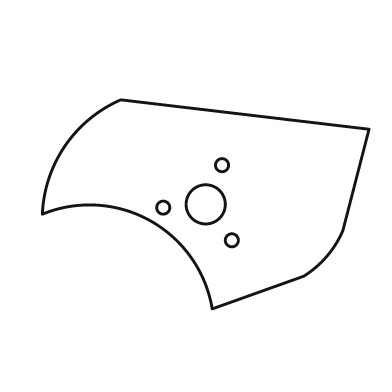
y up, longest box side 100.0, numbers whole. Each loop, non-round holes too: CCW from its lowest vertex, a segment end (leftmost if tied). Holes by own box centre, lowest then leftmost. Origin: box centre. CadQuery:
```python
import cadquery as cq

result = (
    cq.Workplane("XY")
    .moveTo(2.0, -32.0)
    .lineTo(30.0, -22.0)
    .threePointArc((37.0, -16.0), (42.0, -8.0))
    .lineTo(50.0, 23.0)
    .lineTo(-26.0, 32.0)
    .threePointArc((-43.0, 18.0), (-50.0, -3.0))
    .threePointArc((-17.0, -5.0), (2.0, -32.0))
    .close()
    .moveTo(8.0, -11.0)
    .circle(2.0)
    .moveTo(-13.0, -1.0)
    .circle(2.0)
    .moveTo(0.0, 0.0)
    .circle(6.0)
    .moveTo(5.0, 12.0)
    .circle(2.0)
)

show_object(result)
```